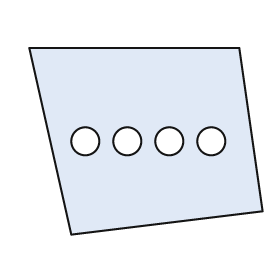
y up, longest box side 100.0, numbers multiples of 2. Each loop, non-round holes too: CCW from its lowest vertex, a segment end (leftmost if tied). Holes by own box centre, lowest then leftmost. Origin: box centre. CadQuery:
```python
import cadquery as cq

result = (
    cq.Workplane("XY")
    .moveTo(-32.0, -40.0)
    .lineTo(50.0, -30.0)
    .lineTo(40.0, 40.0)
    .lineTo(-50.0, 40.0)
    .close()
    .moveTo(-26.0, 0.0)
    .circle(6.0)
    .moveTo(-8.0, 0.0)
    .circle(6.0)
    .moveTo(10.0, 0.0)
    .circle(6.0)
    .moveTo(28.0, 0.0)
    .circle(6.0)
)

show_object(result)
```